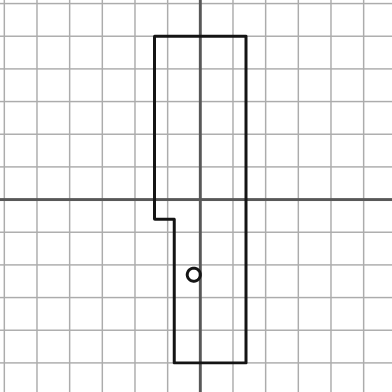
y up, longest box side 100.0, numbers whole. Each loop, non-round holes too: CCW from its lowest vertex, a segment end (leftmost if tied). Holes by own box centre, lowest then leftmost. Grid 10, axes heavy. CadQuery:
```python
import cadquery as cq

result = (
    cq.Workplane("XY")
    .moveTo(-8.0, -50.0)
    .lineTo(14.0, -50.0)
    .lineTo(14.0, 50.0)
    .lineTo(-14.0, 50.0)
    .lineTo(-14.0, -6.0)
    .lineTo(-8.0, -6.0)
    .close()
    .moveTo(-2.0, -23.0)
    .circle(2.0)
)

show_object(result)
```